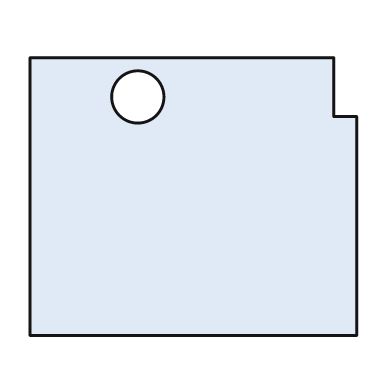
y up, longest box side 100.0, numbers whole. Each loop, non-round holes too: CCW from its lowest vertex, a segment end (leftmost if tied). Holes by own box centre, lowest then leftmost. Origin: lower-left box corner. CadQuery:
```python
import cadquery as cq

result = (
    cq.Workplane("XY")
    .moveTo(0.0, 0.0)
    .lineTo(100.0, 0.0)
    .lineTo(100.0, 67.0)
    .lineTo(93.0, 67.0)
    .lineTo(93.0, 85.0)
    .lineTo(0.0, 85.0)
    .close()
    .moveTo(33.0, 73.0)
    .circle(8.0)
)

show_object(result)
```